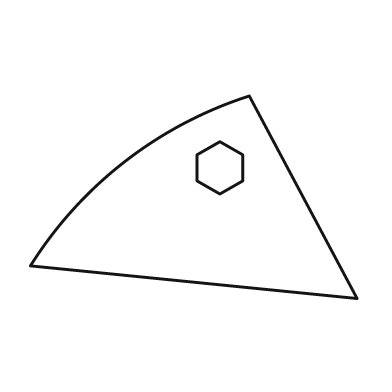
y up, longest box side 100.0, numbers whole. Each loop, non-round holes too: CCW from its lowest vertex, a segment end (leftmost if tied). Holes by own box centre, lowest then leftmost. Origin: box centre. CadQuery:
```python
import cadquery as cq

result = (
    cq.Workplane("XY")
    .moveTo(50.0, -31.0)
    .lineTo(17.0, 31.0)
    .threePointArc((-21.0, 11.0), (-50.0, -21.0))
    .close()
    .moveTo(8.0, 1.0)
    .lineTo(15.0, 5.0)
    .lineTo(15.0, 13.0)
    .lineTo(8.0, 17.0)
    .lineTo(1.0, 13.0)
    .lineTo(1.0, 5.0)
    .close()
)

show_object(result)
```